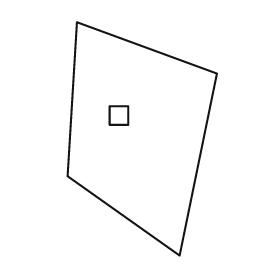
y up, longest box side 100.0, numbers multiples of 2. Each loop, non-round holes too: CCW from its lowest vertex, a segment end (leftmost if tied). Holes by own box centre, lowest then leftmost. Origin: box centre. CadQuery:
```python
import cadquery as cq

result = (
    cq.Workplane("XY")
    .moveTo(16.0, -50.0)
    .lineTo(32.0, 28.0)
    .lineTo(-28.0, 50.0)
    .lineTo(-32.0, -16.0)
    .close()
    .moveTo(-14.0, 6.0)
    .lineTo(-6.0, 6.0)
    .lineTo(-6.0, 14.0)
    .lineTo(-14.0, 14.0)
    .close()
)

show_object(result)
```